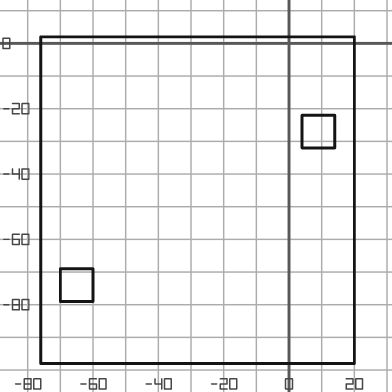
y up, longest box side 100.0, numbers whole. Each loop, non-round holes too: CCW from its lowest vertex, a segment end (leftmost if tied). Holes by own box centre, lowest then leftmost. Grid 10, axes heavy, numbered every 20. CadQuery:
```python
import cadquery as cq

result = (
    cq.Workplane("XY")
    .moveTo(-76.0, -98.0)
    .lineTo(20.0, -98.0)
    .lineTo(20.0, 2.0)
    .lineTo(-76.0, 2.0)
    .close()
    .moveTo(-70.0, -79.0)
    .lineTo(-60.0, -79.0)
    .lineTo(-60.0, -69.0)
    .lineTo(-70.0, -69.0)
    .close()
    .moveTo(4.0, -32.0)
    .lineTo(14.0, -32.0)
    .lineTo(14.0, -22.0)
    .lineTo(4.0, -22.0)
    .close()
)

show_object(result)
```